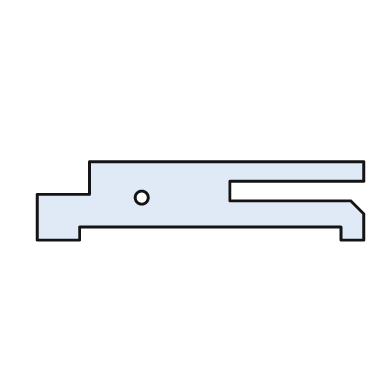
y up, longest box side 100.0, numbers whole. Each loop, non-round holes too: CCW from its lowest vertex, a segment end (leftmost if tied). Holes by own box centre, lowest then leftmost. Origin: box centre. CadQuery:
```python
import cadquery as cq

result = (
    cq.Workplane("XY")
    .moveTo(-50.0, -12.0)
    .lineTo(-37.0, -12.0)
    .lineTo(-37.0, -8.0)
    .lineTo(43.0, -8.0)
    .lineTo(43.0, -12.0)
    .lineTo(50.0, -12.0)
    .lineTo(50.0, -4.0)
    .lineTo(46.0, 0.0)
    .lineTo(9.0, 0.0)
    .lineTo(9.0, 6.0)
    .lineTo(50.0, 6.0)
    .lineTo(50.0, 12.0)
    .lineTo(-34.0, 12.0)
    .lineTo(-34.0, 2.0)
    .lineTo(-50.0, 2.0)
    .close()
    .moveTo(-18.0, 1.0)
    .circle(2.0)
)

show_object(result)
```